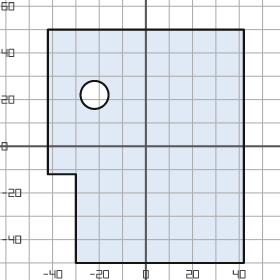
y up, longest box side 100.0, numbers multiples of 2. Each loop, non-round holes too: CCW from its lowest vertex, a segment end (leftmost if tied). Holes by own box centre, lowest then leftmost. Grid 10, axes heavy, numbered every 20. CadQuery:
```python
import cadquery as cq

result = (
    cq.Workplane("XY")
    .moveTo(-30.0, -50.0)
    .lineTo(42.0, -50.0)
    .lineTo(42.0, 50.0)
    .lineTo(-42.0, 50.0)
    .lineTo(-42.0, -12.0)
    .lineTo(-30.0, -12.0)
    .close()
    .moveTo(-22.0, 22.0)
    .circle(6.0)
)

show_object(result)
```